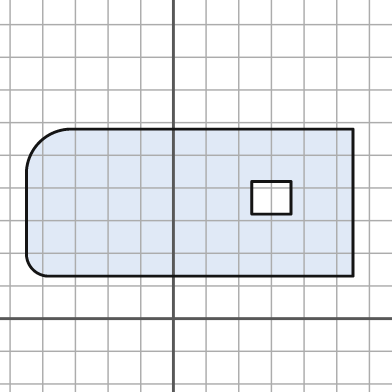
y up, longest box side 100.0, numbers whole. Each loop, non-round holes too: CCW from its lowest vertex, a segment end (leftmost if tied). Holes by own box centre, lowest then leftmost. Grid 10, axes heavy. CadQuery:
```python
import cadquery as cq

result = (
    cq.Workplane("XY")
    .moveTo(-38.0, 13.0)
    .lineTo(55.0, 13.0)
    .lineTo(55.0, 58.0)
    .lineTo(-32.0, 58.0)
    .threePointArc((-41.0, 54.0), (-45.0, 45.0))
    .lineTo(-45.0, 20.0)
    .threePointArc((-43.0, 15.0), (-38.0, 13.0))
    .close()
    .moveTo(24.0, 32.0)
    .lineTo(36.0, 32.0)
    .lineTo(36.0, 42.0)
    .lineTo(24.0, 42.0)
    .close()
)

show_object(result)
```